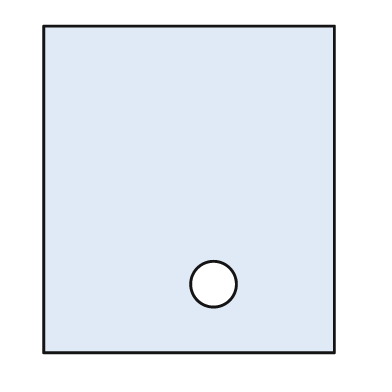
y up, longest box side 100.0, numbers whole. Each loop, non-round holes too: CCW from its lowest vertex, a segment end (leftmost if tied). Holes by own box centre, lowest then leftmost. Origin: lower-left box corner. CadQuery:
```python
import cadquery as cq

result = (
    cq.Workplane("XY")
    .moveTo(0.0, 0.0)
    .lineTo(89.0, 0.0)
    .lineTo(89.0, 100.0)
    .lineTo(0.0, 100.0)
    .close()
    .moveTo(52.0, 21.0)
    .circle(7.0)
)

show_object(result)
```